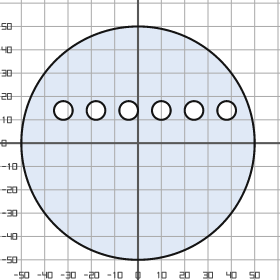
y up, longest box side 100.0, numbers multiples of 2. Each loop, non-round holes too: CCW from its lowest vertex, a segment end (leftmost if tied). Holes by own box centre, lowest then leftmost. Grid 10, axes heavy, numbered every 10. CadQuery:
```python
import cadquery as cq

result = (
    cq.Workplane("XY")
    .moveTo(0.0, 0.0)
    .circle(50.0)
    .moveTo(-32.0, 14.0)
    .circle(4.0)
    .moveTo(-18.0, 14.0)
    .circle(4.0)
    .moveTo(-4.0, 14.0)
    .circle(4.0)
    .moveTo(10.0, 14.0)
    .circle(4.0)
    .moveTo(24.0, 14.0)
    .circle(4.0)
    .moveTo(38.0, 14.0)
    .circle(4.0)
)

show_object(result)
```